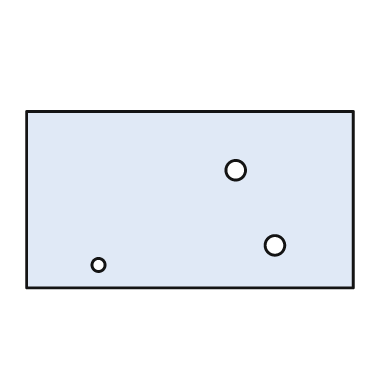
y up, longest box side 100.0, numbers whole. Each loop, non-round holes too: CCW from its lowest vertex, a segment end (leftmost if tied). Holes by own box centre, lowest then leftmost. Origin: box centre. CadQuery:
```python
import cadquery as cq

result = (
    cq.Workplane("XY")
    .moveTo(-50.0, -27.0)
    .lineTo(50.0, -27.0)
    .lineTo(50.0, 27.0)
    .lineTo(-50.0, 27.0)
    .close()
    .moveTo(-28.0, -20.0)
    .circle(2.0)
    .moveTo(26.0, -14.0)
    .circle(3.0)
    .moveTo(14.0, 9.0)
    .circle(3.0)
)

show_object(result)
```